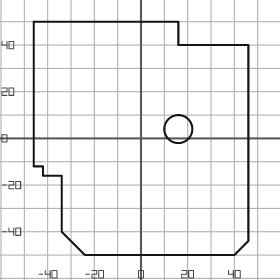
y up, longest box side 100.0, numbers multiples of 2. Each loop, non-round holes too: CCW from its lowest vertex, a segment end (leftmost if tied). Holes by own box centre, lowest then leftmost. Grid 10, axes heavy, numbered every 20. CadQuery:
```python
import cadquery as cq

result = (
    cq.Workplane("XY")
    .moveTo(-24.0, -50.0)
    .lineTo(40.0, -50.0)
    .lineTo(46.0, -44.0)
    .lineTo(46.0, 40.0)
    .lineTo(16.0, 40.0)
    .lineTo(16.0, 50.0)
    .lineTo(-46.0, 50.0)
    .lineTo(-46.0, -12.0)
    .lineTo(-42.0, -12.0)
    .lineTo(-42.0, -16.0)
    .lineTo(-34.0, -16.0)
    .lineTo(-34.0, -40.0)
    .close()
    .moveTo(16.0, 4.0)
    .circle(6.0)
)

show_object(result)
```